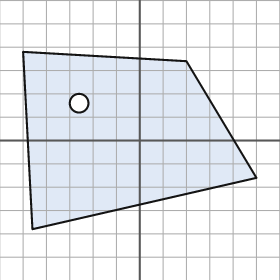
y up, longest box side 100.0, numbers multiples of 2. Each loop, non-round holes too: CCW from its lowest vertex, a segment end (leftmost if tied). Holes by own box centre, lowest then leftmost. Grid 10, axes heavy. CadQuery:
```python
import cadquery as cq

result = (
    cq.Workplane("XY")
    .moveTo(-46.0, -38.0)
    .lineTo(50.0, -16.0)
    .lineTo(20.0, 34.0)
    .lineTo(-50.0, 38.0)
    .close()
    .moveTo(-26.0, 16.0)
    .circle(4.0)
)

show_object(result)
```